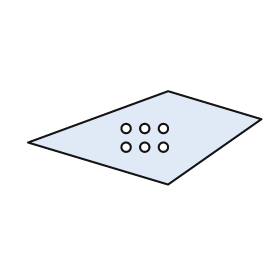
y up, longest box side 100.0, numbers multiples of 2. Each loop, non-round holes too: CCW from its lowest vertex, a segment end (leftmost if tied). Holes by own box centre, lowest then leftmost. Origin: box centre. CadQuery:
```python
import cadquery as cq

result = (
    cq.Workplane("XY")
    .moveTo(10.0, -20.0)
    .lineTo(50.0, 8.0)
    .lineTo(10.0, 20.0)
    .lineTo(-50.0, -2.0)
    .close()
    .moveTo(-8.0, -4.0)
    .circle(2.0)
    .moveTo(0.0, -4.0)
    .circle(2.0)
    .moveTo(8.0, -4.0)
    .circle(2.0)
    .moveTo(-8.0, 4.0)
    .circle(2.0)
    .moveTo(0.0, 4.0)
    .circle(2.0)
    .moveTo(8.0, 4.0)
    .circle(2.0)
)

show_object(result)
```